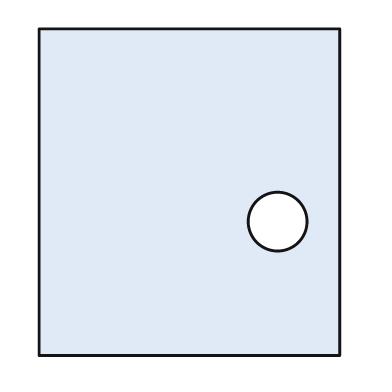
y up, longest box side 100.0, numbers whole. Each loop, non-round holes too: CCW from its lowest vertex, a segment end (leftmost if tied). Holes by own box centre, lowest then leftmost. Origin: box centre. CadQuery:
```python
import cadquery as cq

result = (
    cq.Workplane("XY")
    .moveTo(-46.0, -50.0)
    .lineTo(46.0, -50.0)
    .lineTo(46.0, 50.0)
    .lineTo(-46.0, 50.0)
    .close()
    .moveTo(27.0, -9.0)
    .circle(9.0)
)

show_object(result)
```